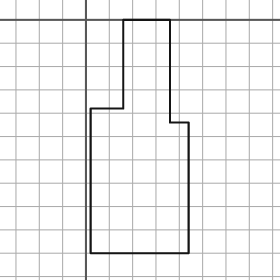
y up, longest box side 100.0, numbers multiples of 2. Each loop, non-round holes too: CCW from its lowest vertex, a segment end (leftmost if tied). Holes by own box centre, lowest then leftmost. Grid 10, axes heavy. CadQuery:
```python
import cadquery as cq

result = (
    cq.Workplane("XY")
    .moveTo(2.0, -100.0)
    .lineTo(44.0, -100.0)
    .lineTo(44.0, -44.0)
    .lineTo(36.0, -44.0)
    .lineTo(36.0, 0.0)
    .lineTo(16.0, 0.0)
    .lineTo(16.0, -38.0)
    .lineTo(2.0, -38.0)
    .close()
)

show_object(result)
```